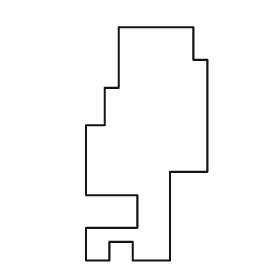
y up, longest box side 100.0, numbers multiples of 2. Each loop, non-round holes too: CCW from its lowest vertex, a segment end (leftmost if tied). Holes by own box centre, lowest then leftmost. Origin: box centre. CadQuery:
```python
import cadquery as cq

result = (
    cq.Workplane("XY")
    .moveTo(-26.0, -50.0)
    .lineTo(-16.0, -50.0)
    .lineTo(-16.0, -42.0)
    .lineTo(-6.0, -42.0)
    .lineTo(-6.0, -50.0)
    .lineTo(10.0, -50.0)
    .lineTo(10.0, -12.0)
    .lineTo(26.0, -12.0)
    .lineTo(26.0, 36.0)
    .lineTo(20.0, 36.0)
    .lineTo(20.0, 50.0)
    .lineTo(-12.0, 50.0)
    .lineTo(-12.0, 24.0)
    .lineTo(-18.0, 24.0)
    .lineTo(-18.0, 8.0)
    .lineTo(-26.0, 8.0)
    .lineTo(-26.0, -22.0)
    .lineTo(-4.0, -22.0)
    .lineTo(-4.0, -36.0)
    .lineTo(-26.0, -36.0)
    .close()
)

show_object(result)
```